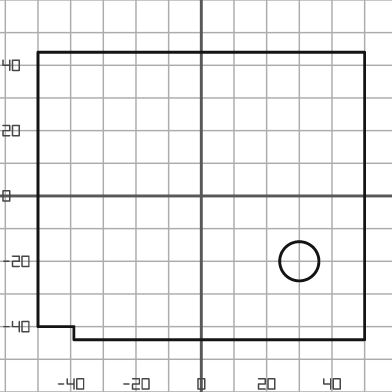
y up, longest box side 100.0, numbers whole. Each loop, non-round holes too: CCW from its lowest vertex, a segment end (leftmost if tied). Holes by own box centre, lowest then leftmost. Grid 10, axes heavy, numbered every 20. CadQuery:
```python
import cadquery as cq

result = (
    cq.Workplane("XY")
    .moveTo(-39.0, -44.0)
    .lineTo(50.0, -44.0)
    .lineTo(50.0, 44.0)
    .lineTo(-50.0, 44.0)
    .lineTo(-50.0, -40.0)
    .lineTo(-39.0, -40.0)
    .close()
    .moveTo(30.0, -20.0)
    .circle(6.0)
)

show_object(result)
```